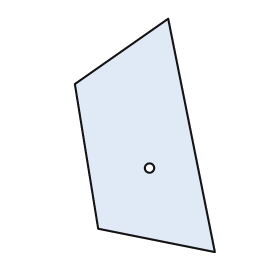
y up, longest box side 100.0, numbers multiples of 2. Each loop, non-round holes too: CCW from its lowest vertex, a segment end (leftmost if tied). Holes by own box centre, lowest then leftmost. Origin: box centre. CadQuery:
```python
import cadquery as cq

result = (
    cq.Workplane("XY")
    .moveTo(30.0, -50.0)
    .lineTo(10.0, 50.0)
    .lineTo(-30.0, 22.0)
    .lineTo(-20.0, -40.0)
    .close()
    .moveTo(2.0, -14.0)
    .circle(2.0)
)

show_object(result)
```